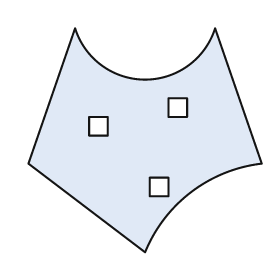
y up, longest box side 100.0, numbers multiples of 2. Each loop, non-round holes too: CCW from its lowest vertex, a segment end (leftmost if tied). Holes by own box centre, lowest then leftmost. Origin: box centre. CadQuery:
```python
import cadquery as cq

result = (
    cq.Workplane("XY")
    .moveTo(0.0, -48.0)
    .threePointArc((20.0, -22.0), (50.0, -10.0))
    .lineTo(30.0, 48.0)
    .threePointArc((0.0, 26.0), (-30.0, 48.0))
    .lineTo(-50.0, -10.0)
    .close()
    .moveTo(2.0, -24.0)
    .lineTo(10.0, -24.0)
    .lineTo(10.0, -16.0)
    .lineTo(2.0, -16.0)
    .close()
    .moveTo(-24.0, 2.0)
    .lineTo(-16.0, 2.0)
    .lineTo(-16.0, 10.0)
    .lineTo(-24.0, 10.0)
    .close()
    .moveTo(10.0, 10.0)
    .lineTo(18.0, 10.0)
    .lineTo(18.0, 18.0)
    .lineTo(10.0, 18.0)
    .close()
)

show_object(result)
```